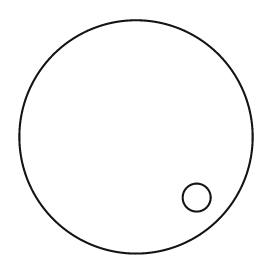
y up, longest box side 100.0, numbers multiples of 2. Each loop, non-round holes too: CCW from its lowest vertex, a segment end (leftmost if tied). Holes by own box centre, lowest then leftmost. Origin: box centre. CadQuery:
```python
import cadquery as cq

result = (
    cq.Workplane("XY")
    .moveTo(0.0, 0.0)
    .circle(50.0)
    .moveTo(26.0, -26.0)
    .circle(6.0)
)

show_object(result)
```